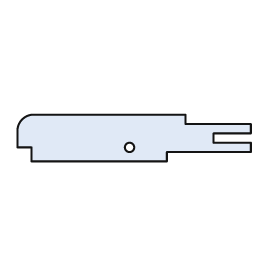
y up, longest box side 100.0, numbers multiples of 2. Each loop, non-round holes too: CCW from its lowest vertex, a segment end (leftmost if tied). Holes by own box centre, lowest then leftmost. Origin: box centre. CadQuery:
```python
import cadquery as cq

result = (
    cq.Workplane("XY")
    .moveTo(-44.0, -10.0)
    .lineTo(14.0, -10.0)
    .lineTo(14.0, -6.0)
    .lineTo(50.0, -6.0)
    .lineTo(50.0, -2.0)
    .lineTo(34.0, -2.0)
    .lineTo(34.0, 2.0)
    .lineTo(50.0, 2.0)
    .lineTo(50.0, 6.0)
    .lineTo(22.0, 6.0)
    .lineTo(22.0, 10.0)
    .lineTo(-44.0, 10.0)
    .threePointArc((-48.0, 8.0), (-50.0, 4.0))
    .lineTo(-50.0, -4.0)
    .lineTo(-44.0, -4.0)
    .close()
    .moveTo(-2.0, -4.0)
    .circle(2.0)
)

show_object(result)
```